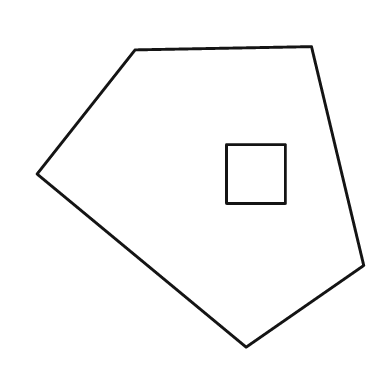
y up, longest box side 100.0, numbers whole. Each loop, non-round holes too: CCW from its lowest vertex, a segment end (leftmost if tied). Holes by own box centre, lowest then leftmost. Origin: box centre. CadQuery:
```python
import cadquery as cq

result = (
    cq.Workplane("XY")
    .moveTo(14.0, -46.0)
    .lineTo(50.0, -21.0)
    .lineTo(34.0, 46.0)
    .lineTo(-20.0, 45.0)
    .lineTo(-50.0, 7.0)
    .close()
    .moveTo(8.0, -2.0)
    .lineTo(26.0, -2.0)
    .lineTo(26.0, 16.0)
    .lineTo(8.0, 16.0)
    .close()
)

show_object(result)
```